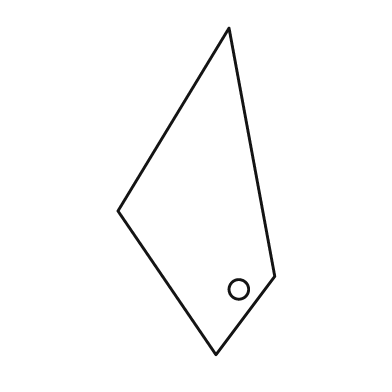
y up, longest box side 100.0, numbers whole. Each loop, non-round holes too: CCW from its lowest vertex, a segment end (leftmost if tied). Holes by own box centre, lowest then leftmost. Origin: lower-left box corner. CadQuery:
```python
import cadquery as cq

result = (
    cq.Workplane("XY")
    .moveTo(30.0, 0.0)
    .lineTo(48.0, 24.0)
    .lineTo(34.0, 100.0)
    .lineTo(0.0, 44.0)
    .close()
    .moveTo(37.0, 20.0)
    .circle(3.0)
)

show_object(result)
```